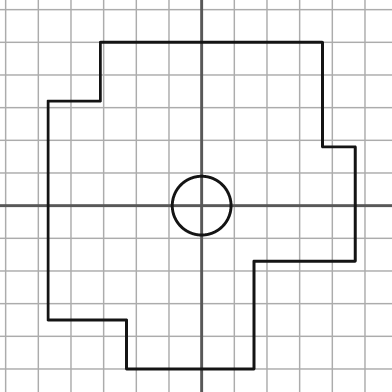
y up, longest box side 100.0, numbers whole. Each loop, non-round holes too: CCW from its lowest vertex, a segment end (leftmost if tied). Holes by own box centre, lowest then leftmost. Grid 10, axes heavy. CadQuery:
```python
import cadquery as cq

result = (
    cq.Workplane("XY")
    .moveTo(-23.0, -50.0)
    .lineTo(16.0, -50.0)
    .lineTo(16.0, -17.0)
    .lineTo(47.0, -17.0)
    .lineTo(47.0, 18.0)
    .lineTo(37.0, 18.0)
    .lineTo(37.0, 50.0)
    .lineTo(-31.0, 50.0)
    .lineTo(-31.0, 32.0)
    .lineTo(-47.0, 32.0)
    .lineTo(-47.0, -35.0)
    .lineTo(-23.0, -35.0)
    .close()
    .moveTo(0.0, 0.0)
    .circle(9.0)
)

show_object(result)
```